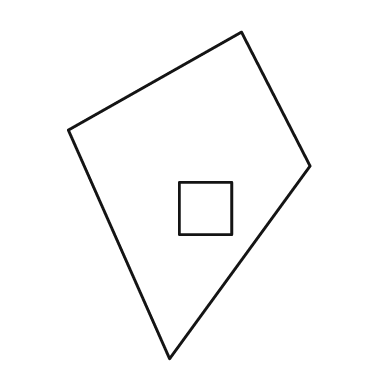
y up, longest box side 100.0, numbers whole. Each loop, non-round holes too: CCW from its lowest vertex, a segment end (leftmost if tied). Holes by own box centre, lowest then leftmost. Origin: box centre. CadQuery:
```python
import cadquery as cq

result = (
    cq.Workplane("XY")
    .moveTo(-6.0, -50.0)
    .lineTo(37.0, 9.0)
    .lineTo(16.0, 50.0)
    .lineTo(-37.0, 20.0)
    .close()
    .moveTo(-3.0, -12.0)
    .lineTo(13.0, -12.0)
    .lineTo(13.0, 4.0)
    .lineTo(-3.0, 4.0)
    .close()
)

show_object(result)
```